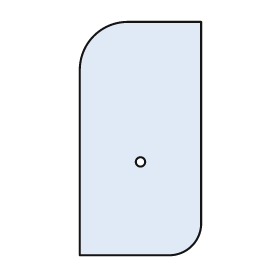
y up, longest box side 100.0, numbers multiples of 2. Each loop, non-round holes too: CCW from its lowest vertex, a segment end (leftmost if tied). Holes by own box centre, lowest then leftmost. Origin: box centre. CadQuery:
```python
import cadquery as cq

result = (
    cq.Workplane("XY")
    .moveTo(-26.0, -50.0)
    .lineTo(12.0, -50.0)
    .threePointArc((22.0, -46.0), (26.0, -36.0))
    .lineTo(26.0, 50.0)
    .lineTo(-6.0, 50.0)
    .threePointArc((-20.0, 44.0), (-26.0, 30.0))
    .close()
    .moveTo(0.0, -10.0)
    .circle(2.0)
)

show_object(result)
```